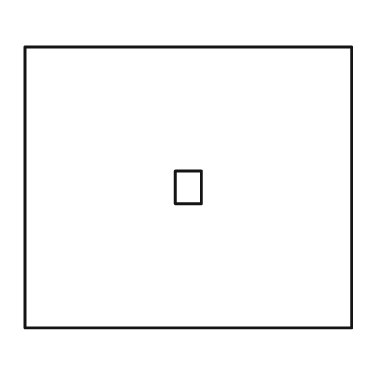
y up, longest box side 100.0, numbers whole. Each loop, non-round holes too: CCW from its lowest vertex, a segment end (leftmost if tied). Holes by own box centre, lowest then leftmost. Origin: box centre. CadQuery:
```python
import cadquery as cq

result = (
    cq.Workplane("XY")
    .moveTo(-50.0, -43.0)
    .lineTo(50.0, -43.0)
    .lineTo(50.0, 43.0)
    .lineTo(-50.0, 43.0)
    .close()
    .moveTo(-4.0, -5.0)
    .lineTo(4.0, -5.0)
    .lineTo(4.0, 5.0)
    .lineTo(-4.0, 5.0)
    .close()
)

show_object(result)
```